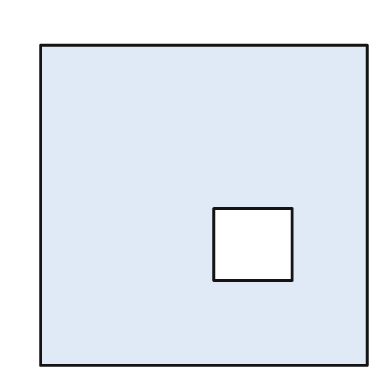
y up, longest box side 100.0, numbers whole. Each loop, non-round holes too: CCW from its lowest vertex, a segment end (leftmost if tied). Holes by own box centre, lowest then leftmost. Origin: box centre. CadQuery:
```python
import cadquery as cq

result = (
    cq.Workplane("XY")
    .moveTo(-50.0, -49.0)
    .lineTo(50.0, -49.0)
    .lineTo(50.0, 49.0)
    .lineTo(-50.0, 49.0)
    .close()
    .moveTo(3.0, -23.0)
    .lineTo(27.0, -23.0)
    .lineTo(27.0, -1.0)
    .lineTo(3.0, -1.0)
    .close()
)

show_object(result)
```